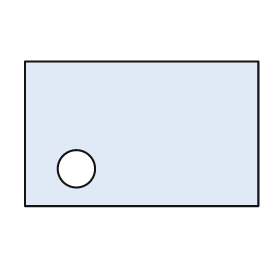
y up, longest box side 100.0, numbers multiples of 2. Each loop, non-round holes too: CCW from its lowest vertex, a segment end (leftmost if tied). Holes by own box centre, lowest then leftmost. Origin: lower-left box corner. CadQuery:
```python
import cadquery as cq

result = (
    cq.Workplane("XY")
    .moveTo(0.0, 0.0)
    .lineTo(100.0, 0.0)
    .lineTo(100.0, 62.0)
    .lineTo(0.0, 62.0)
    .close()
    .moveTo(22.0, 16.0)
    .circle(8.0)
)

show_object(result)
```